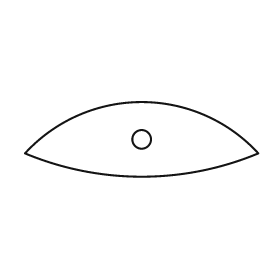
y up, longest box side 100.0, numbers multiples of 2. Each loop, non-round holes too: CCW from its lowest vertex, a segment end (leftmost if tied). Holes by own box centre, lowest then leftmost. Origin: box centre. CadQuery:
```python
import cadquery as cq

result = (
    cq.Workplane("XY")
    .moveTo(-50.0, -6.0)
    .threePointArc((0.0, -16.0), (50.0, -6.0))
    .threePointArc((0.0, 16.0), (-50.0, -6.0))
    .close()
    .moveTo(0.0, 0.0)
    .circle(4.0)
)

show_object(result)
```